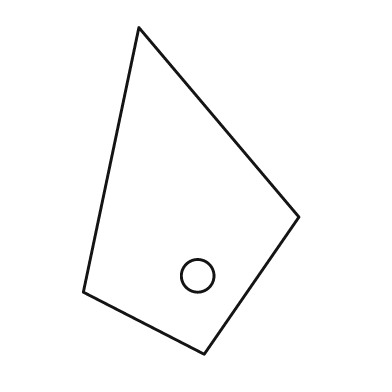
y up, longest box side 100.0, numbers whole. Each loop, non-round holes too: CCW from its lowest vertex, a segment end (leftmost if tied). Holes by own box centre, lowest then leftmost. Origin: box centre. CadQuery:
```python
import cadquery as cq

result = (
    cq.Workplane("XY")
    .moveTo(4.0, -50.0)
    .lineTo(33.0, -8.0)
    .lineTo(-16.0, 50.0)
    .lineTo(-33.0, -31.0)
    .close()
    .moveTo(2.0, -26.0)
    .circle(5.0)
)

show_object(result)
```